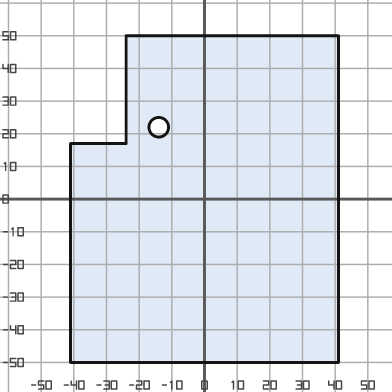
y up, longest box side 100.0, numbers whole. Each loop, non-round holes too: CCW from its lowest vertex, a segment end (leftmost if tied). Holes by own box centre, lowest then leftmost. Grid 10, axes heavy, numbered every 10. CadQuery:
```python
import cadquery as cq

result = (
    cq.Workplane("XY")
    .moveTo(-41.0, -50.0)
    .lineTo(41.0, -50.0)
    .lineTo(41.0, 50.0)
    .lineTo(-24.0, 50.0)
    .lineTo(-24.0, 17.0)
    .lineTo(-41.0, 17.0)
    .close()
    .moveTo(-14.0, 22.0)
    .circle(3.0)
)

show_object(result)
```